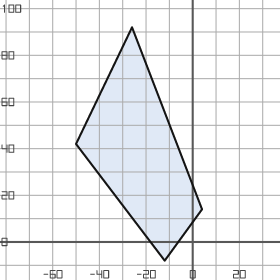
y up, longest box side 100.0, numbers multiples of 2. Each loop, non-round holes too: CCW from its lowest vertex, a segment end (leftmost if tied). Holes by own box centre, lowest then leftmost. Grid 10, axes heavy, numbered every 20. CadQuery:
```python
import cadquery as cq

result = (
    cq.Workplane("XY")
    .moveTo(-12.0, -8.0)
    .lineTo(4.0, 14.0)
    .lineTo(-26.0, 92.0)
    .lineTo(-50.0, 42.0)
    .close()
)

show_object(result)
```